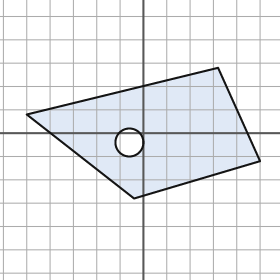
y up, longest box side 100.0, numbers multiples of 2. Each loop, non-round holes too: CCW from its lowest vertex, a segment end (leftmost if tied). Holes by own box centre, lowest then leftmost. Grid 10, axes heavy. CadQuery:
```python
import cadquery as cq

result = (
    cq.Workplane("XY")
    .moveTo(-4.0, -28.0)
    .lineTo(50.0, -12.0)
    .lineTo(32.0, 28.0)
    .lineTo(-50.0, 8.0)
    .close()
    .moveTo(-6.0, -4.0)
    .circle(6.0)
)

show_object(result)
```